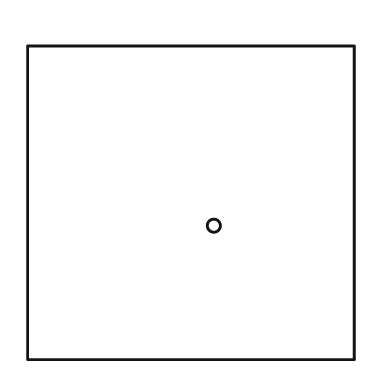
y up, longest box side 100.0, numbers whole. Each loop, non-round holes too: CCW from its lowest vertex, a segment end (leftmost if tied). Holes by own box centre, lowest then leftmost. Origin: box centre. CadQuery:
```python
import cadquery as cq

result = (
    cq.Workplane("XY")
    .moveTo(-50.0, -48.0)
    .lineTo(50.0, -48.0)
    .lineTo(50.0, 48.0)
    .lineTo(-50.0, 48.0)
    .close()
    .moveTo(7.0, -7.0)
    .circle(2.0)
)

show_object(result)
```